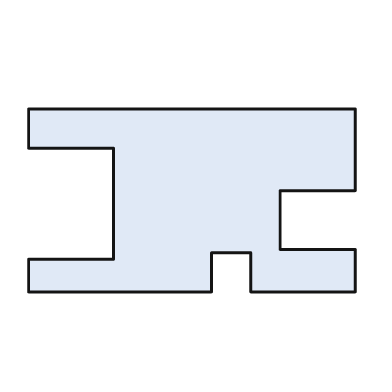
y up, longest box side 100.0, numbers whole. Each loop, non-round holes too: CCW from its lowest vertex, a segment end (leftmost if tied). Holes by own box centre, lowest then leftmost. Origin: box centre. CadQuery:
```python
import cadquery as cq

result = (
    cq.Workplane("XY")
    .moveTo(-50.0, -28.0)
    .lineTo(6.0, -28.0)
    .lineTo(6.0, -16.0)
    .lineTo(18.0, -16.0)
    .lineTo(18.0, -28.0)
    .lineTo(50.0, -28.0)
    .lineTo(50.0, -15.0)
    .lineTo(27.0, -15.0)
    .lineTo(27.0, 3.0)
    .lineTo(50.0, 3.0)
    .lineTo(50.0, 28.0)
    .lineTo(-50.0, 28.0)
    .lineTo(-50.0, 16.0)
    .lineTo(-24.0, 16.0)
    .lineTo(-24.0, -18.0)
    .lineTo(-50.0, -18.0)
    .close()
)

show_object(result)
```